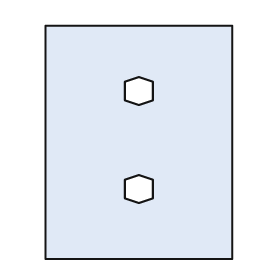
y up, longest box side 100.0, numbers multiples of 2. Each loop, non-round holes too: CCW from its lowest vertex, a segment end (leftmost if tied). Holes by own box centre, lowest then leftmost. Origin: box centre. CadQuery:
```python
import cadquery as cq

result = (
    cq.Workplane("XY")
    .moveTo(-40.0, -50.0)
    .lineTo(40.0, -50.0)
    .lineTo(40.0, 50.0)
    .lineTo(-40.0, 50.0)
    .close()
    .moveTo(0.0, -26.0)
    .lineTo(6.0, -24.0)
    .lineTo(6.0, -16.0)
    .lineTo(0.0, -14.0)
    .lineTo(-6.0, -16.0)
    .lineTo(-6.0, -24.0)
    .close()
    .moveTo(0.0, 16.0)
    .lineTo(6.0, 18.0)
    .lineTo(6.0, 26.0)
    .lineTo(0.0, 28.0)
    .lineTo(-6.0, 26.0)
    .lineTo(-6.0, 18.0)
    .close()
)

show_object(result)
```